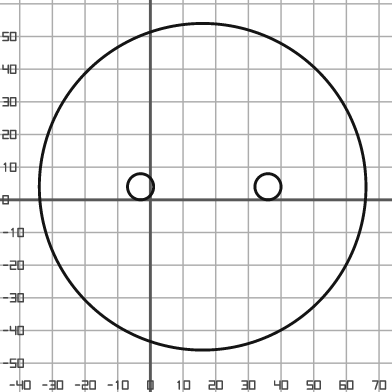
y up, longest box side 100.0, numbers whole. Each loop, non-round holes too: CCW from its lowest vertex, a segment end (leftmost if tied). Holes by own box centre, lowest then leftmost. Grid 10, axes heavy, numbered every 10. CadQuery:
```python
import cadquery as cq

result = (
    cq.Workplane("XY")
    .moveTo(16.0, 4.0)
    .circle(50.0)
    .moveTo(-3.0, 4.0)
    .circle(4.0)
    .moveTo(36.0, 4.0)
    .circle(4.0)
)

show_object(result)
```